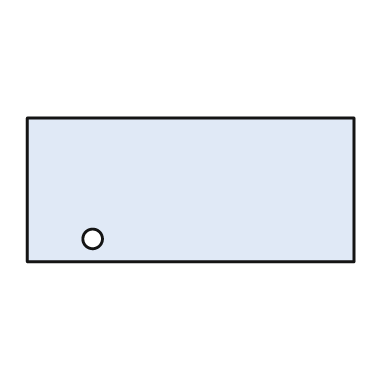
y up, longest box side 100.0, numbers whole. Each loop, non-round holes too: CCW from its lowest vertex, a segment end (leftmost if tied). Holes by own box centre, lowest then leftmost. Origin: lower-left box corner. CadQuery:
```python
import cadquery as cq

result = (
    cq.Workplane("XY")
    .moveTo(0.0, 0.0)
    .lineTo(100.0, 0.0)
    .lineTo(100.0, 44.0)
    .lineTo(0.0, 44.0)
    .close()
    .moveTo(20.0, 7.0)
    .circle(3.0)
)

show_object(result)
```